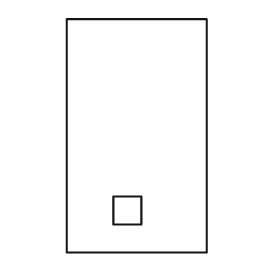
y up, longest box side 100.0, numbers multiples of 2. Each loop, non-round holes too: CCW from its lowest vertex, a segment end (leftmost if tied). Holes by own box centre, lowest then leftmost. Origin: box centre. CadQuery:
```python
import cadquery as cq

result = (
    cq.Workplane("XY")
    .moveTo(-30.0, -50.0)
    .lineTo(30.0, -50.0)
    .lineTo(30.0, 50.0)
    .lineTo(-30.0, 50.0)
    .close()
    .moveTo(-10.0, -38.0)
    .lineTo(2.0, -38.0)
    .lineTo(2.0, -26.0)
    .lineTo(-10.0, -26.0)
    .close()
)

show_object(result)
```